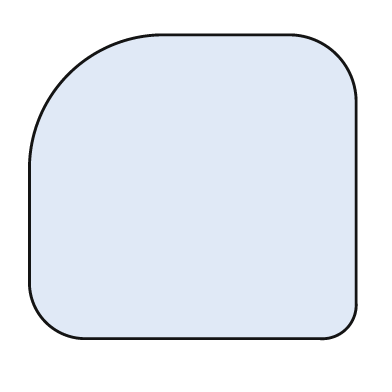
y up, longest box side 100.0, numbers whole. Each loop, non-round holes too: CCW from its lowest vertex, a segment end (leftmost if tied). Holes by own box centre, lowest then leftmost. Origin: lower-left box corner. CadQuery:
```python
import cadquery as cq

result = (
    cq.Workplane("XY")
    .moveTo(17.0, 0.0)
    .lineTo(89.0, 0.0)
    .threePointArc((97.0, 3.0), (100.0, 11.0))
    .lineTo(100.0, 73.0)
    .threePointArc((94.0, 87.0), (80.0, 93.0))
    .lineTo(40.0, 93.0)
    .threePointArc((12.0, 81.0), (0.0, 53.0))
    .lineTo(0.0, 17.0)
    .threePointArc((5.0, 5.0), (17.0, 0.0))
    .close()
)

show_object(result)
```